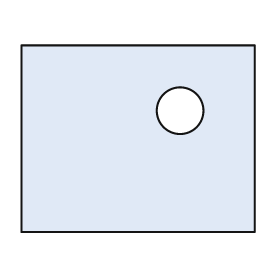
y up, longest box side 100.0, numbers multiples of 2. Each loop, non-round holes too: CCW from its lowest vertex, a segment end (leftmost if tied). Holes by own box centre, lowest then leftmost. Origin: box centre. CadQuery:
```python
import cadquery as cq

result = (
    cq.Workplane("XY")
    .moveTo(-50.0, -40.0)
    .lineTo(50.0, -40.0)
    .lineTo(50.0, 40.0)
    .lineTo(-50.0, 40.0)
    .close()
    .moveTo(18.0, 12.0)
    .circle(10.0)
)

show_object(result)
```